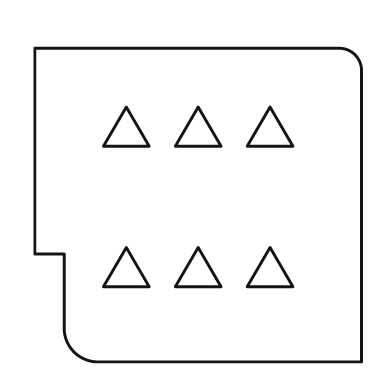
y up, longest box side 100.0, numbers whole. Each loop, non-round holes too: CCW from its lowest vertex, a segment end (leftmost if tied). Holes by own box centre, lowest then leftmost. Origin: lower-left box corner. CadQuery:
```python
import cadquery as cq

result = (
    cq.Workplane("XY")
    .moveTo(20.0, 0.0)
    .lineTo(100.0, 0.0)
    .lineTo(100.0, 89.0)
    .threePointArc((98.0, 94.0), (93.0, 96.0))
    .lineTo(0.0, 96.0)
    .lineTo(0.0, 33.0)
    .lineTo(9.0, 33.0)
    .lineTo(9.0, 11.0)
    .threePointArc((12.0, 3.0), (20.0, 0.0))
    .close()
    .moveTo(21.0, 23.0)
    .lineTo(35.0, 23.0)
    .lineTo(28.0, 35.0)
    .close()
    .moveTo(43.0, 23.0)
    .lineTo(57.0, 23.0)
    .lineTo(50.0, 35.0)
    .close()
    .moveTo(65.0, 23.0)
    .lineTo(79.0, 23.0)
    .lineTo(72.0, 35.0)
    .close()
    .moveTo(21.0, 66.0)
    .lineTo(35.0, 66.0)
    .lineTo(28.0, 78.0)
    .close()
    .moveTo(43.0, 66.0)
    .lineTo(57.0, 66.0)
    .lineTo(50.0, 78.0)
    .close()
    .moveTo(65.0, 66.0)
    .lineTo(79.0, 66.0)
    .lineTo(72.0, 78.0)
    .close()
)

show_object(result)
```